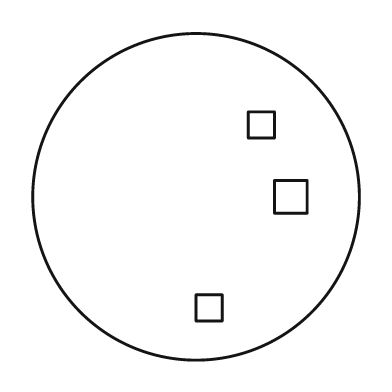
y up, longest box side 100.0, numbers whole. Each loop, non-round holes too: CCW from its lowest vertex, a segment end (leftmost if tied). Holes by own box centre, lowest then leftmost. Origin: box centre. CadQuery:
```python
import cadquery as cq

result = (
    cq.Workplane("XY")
    .moveTo(0.0, 0.0)
    .circle(50.0)
    .moveTo(0.0, -38.0)
    .lineTo(8.0, -38.0)
    .lineTo(8.0, -30.0)
    .lineTo(0.0, -30.0)
    .close()
    .moveTo(24.0, -5.0)
    .lineTo(34.0, -5.0)
    .lineTo(34.0, 5.0)
    .lineTo(24.0, 5.0)
    .close()
    .moveTo(16.0, 18.0)
    .lineTo(24.0, 18.0)
    .lineTo(24.0, 26.0)
    .lineTo(16.0, 26.0)
    .close()
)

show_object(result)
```